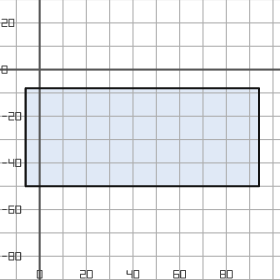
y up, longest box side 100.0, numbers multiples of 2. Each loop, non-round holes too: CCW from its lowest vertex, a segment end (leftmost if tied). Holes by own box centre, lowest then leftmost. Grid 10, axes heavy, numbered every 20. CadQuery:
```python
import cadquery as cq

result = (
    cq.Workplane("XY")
    .moveTo(-6.0, -50.0)
    .lineTo(94.0, -50.0)
    .lineTo(94.0, -8.0)
    .lineTo(-6.0, -8.0)
    .close()
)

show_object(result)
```